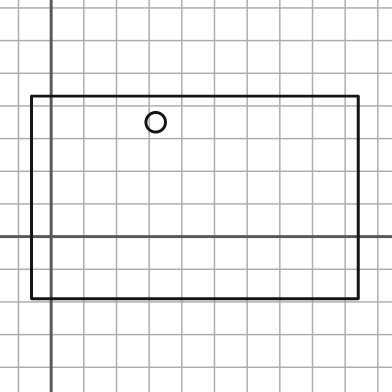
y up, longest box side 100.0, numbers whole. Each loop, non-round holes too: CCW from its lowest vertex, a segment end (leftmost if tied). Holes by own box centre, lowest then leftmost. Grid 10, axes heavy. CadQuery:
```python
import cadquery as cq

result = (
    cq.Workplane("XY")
    .moveTo(-6.0, -19.0)
    .lineTo(94.0, -19.0)
    .lineTo(94.0, 43.0)
    .lineTo(-6.0, 43.0)
    .close()
    .moveTo(32.0, 35.0)
    .circle(3.0)
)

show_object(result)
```